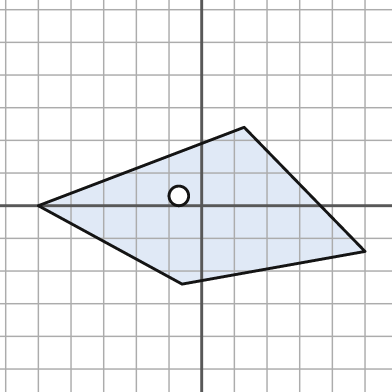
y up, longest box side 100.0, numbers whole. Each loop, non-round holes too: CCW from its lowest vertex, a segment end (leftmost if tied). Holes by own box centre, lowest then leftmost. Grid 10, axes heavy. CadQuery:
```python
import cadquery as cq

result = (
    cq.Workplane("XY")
    .moveTo(-6.0, -24.0)
    .lineTo(50.0, -14.0)
    .lineTo(13.0, 24.0)
    .lineTo(-50.0, 0.0)
    .close()
    .moveTo(-7.0, 3.0)
    .circle(3.0)
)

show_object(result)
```